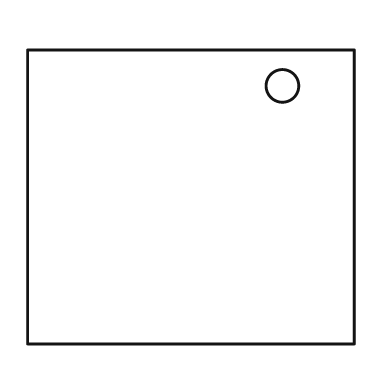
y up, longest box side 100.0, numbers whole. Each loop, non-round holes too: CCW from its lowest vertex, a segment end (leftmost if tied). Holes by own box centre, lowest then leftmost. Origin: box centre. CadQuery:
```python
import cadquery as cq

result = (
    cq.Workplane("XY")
    .moveTo(-50.0, -45.0)
    .lineTo(50.0, -45.0)
    .lineTo(50.0, 45.0)
    .lineTo(-50.0, 45.0)
    .close()
    .moveTo(28.0, 34.0)
    .circle(5.0)
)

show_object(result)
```